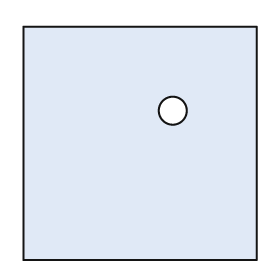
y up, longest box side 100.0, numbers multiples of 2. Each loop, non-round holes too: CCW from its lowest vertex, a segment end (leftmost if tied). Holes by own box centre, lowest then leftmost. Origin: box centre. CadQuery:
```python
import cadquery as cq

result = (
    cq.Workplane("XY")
    .moveTo(-50.0, -50.0)
    .lineTo(50.0, -50.0)
    .lineTo(50.0, 50.0)
    .lineTo(-50.0, 50.0)
    .close()
    .moveTo(14.0, 14.0)
    .circle(6.0)
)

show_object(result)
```